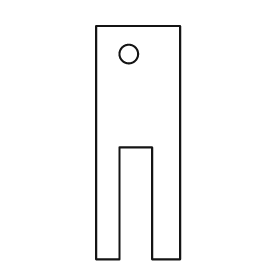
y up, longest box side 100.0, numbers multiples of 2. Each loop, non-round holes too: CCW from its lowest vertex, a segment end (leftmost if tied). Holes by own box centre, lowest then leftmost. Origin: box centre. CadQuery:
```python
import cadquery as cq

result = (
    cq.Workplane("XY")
    .moveTo(-18.0, -50.0)
    .lineTo(-8.0, -50.0)
    .lineTo(-8.0, -2.0)
    .lineTo(6.0, -2.0)
    .lineTo(6.0, -50.0)
    .lineTo(18.0, -50.0)
    .lineTo(18.0, 50.0)
    .lineTo(-18.0, 50.0)
    .close()
    .moveTo(-4.0, 38.0)
    .circle(4.0)
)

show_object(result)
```